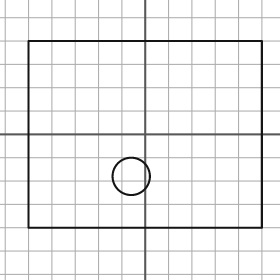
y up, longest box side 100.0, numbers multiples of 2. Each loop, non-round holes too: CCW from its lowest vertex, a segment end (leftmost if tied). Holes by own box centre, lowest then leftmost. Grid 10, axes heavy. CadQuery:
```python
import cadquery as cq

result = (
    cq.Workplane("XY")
    .moveTo(-50.0, -40.0)
    .lineTo(50.0, -40.0)
    .lineTo(50.0, 40.0)
    .lineTo(-50.0, 40.0)
    .close()
    .moveTo(-6.0, -18.0)
    .circle(8.0)
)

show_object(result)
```